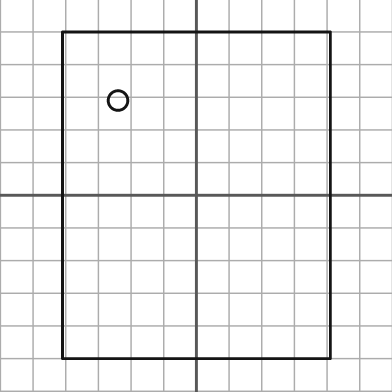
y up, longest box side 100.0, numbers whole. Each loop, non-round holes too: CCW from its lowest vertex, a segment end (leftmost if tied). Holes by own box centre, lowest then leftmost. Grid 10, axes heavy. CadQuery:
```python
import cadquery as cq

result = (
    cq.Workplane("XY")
    .moveTo(-41.0, -50.0)
    .lineTo(41.0, -50.0)
    .lineTo(41.0, 50.0)
    .lineTo(-41.0, 50.0)
    .close()
    .moveTo(-24.0, 29.0)
    .circle(3.0)
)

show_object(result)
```